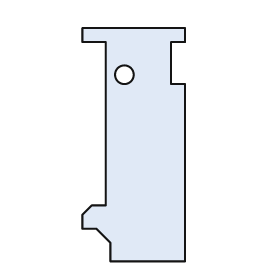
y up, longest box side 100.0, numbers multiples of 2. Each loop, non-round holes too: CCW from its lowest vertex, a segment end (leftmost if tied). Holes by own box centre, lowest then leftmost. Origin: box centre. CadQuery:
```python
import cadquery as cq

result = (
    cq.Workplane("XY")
    .moveTo(-10.0, -50.0)
    .lineTo(22.0, -50.0)
    .lineTo(22.0, 26.0)
    .lineTo(16.0, 26.0)
    .lineTo(16.0, 44.0)
    .lineTo(22.0, 44.0)
    .lineTo(22.0, 50.0)
    .lineTo(-22.0, 50.0)
    .lineTo(-22.0, 44.0)
    .lineTo(-12.0, 44.0)
    .lineTo(-12.0, -26.0)
    .lineTo(-18.0, -26.0)
    .lineTo(-22.0, -30.0)
    .lineTo(-22.0, -36.0)
    .lineTo(-16.0, -36.0)
    .lineTo(-10.0, -42.0)
    .close()
    .moveTo(-4.0, 30.0)
    .circle(4.0)
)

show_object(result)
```